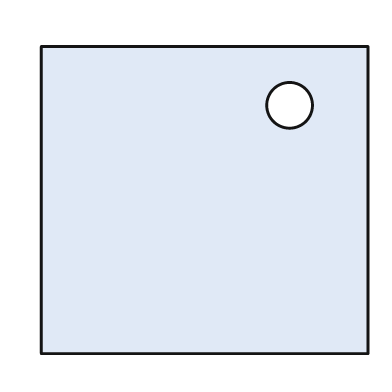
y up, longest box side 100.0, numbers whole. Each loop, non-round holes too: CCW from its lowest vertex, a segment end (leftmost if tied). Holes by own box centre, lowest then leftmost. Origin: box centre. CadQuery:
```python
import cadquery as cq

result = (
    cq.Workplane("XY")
    .moveTo(-50.0, -47.0)
    .lineTo(50.0, -47.0)
    .lineTo(50.0, 47.0)
    .lineTo(-50.0, 47.0)
    .close()
    .moveTo(26.0, 29.0)
    .circle(7.0)
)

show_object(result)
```